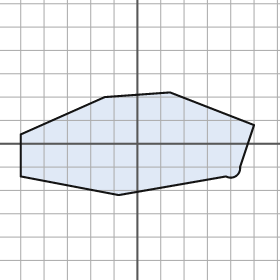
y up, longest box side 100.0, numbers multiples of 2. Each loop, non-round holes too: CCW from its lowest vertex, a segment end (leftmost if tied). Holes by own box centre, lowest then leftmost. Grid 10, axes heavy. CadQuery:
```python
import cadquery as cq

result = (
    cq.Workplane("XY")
    .moveTo(-8.0, -22.0)
    .lineTo(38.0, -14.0)
    .threePointArc((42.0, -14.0), (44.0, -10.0))
    .lineTo(50.0, 8.0)
    .lineTo(14.0, 22.0)
    .lineTo(-14.0, 20.0)
    .lineTo(-50.0, 4.0)
    .lineTo(-50.0, -14.0)
    .close()
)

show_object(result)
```